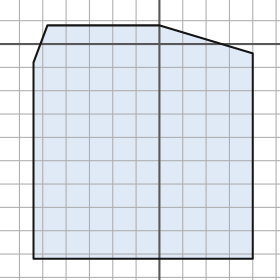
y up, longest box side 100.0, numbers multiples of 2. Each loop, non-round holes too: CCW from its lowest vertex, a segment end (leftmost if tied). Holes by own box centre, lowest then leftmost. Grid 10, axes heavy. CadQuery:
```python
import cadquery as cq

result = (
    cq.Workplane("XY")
    .moveTo(-54.0, -92.0)
    .lineTo(40.0, -92.0)
    .lineTo(40.0, -4.0)
    .lineTo(0.0, 8.0)
    .lineTo(-48.0, 8.0)
    .lineTo(-54.0, -8.0)
    .close()
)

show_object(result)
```